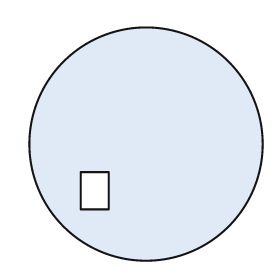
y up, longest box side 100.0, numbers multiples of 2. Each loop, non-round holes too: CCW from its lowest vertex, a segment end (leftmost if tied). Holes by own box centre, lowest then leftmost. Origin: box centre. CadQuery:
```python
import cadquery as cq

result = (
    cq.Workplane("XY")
    .moveTo(0.0, 0.0)
    .circle(50.0)
    .moveTo(-28.0, -28.0)
    .lineTo(-16.0, -28.0)
    .lineTo(-16.0, -12.0)
    .lineTo(-28.0, -12.0)
    .close()
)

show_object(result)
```